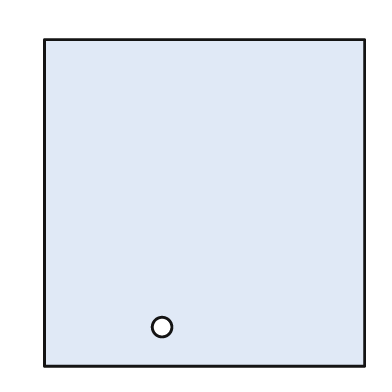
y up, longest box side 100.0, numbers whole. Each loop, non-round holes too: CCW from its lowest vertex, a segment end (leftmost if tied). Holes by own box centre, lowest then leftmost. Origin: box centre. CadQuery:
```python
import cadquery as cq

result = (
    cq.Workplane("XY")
    .moveTo(-49.0, -50.0)
    .lineTo(49.0, -50.0)
    .lineTo(49.0, 50.0)
    .lineTo(-49.0, 50.0)
    .close()
    .moveTo(-13.0, -38.0)
    .circle(3.0)
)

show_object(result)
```